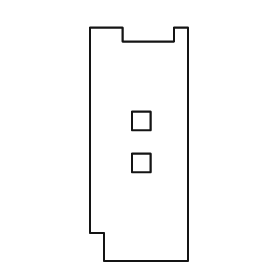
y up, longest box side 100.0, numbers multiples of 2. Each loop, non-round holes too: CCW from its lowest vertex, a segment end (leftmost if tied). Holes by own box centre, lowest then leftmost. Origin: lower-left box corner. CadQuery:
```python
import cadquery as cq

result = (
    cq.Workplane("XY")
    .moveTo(6.0, 0.0)
    .lineTo(42.0, 0.0)
    .lineTo(42.0, 100.0)
    .lineTo(36.0, 100.0)
    .lineTo(36.0, 94.0)
    .lineTo(14.0, 94.0)
    .lineTo(14.0, 100.0)
    .lineTo(0.0, 100.0)
    .lineTo(0.0, 12.0)
    .lineTo(6.0, 12.0)
    .close()
    .moveTo(18.0, 38.0)
    .lineTo(26.0, 38.0)
    .lineTo(26.0, 46.0)
    .lineTo(18.0, 46.0)
    .close()
    .moveTo(18.0, 56.0)
    .lineTo(26.0, 56.0)
    .lineTo(26.0, 64.0)
    .lineTo(18.0, 64.0)
    .close()
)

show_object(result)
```